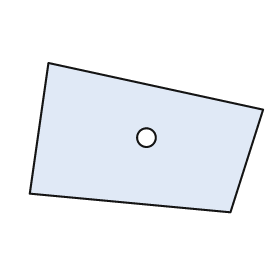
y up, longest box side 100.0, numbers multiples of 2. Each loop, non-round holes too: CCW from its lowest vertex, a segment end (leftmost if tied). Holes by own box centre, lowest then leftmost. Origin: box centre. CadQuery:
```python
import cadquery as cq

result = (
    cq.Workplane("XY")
    .moveTo(36.0, -32.0)
    .lineTo(50.0, 12.0)
    .lineTo(-42.0, 32.0)
    .lineTo(-50.0, -24.0)
    .close()
    .moveTo(0.0, 0.0)
    .circle(4.0)
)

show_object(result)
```